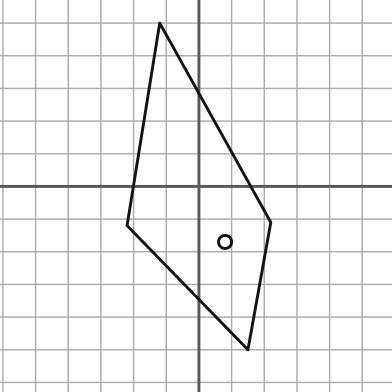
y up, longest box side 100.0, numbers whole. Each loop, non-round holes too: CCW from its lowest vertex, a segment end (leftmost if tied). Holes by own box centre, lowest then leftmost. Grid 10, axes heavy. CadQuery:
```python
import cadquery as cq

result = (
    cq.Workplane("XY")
    .moveTo(15.0, -50.0)
    .lineTo(22.0, -11.0)
    .lineTo(-12.0, 50.0)
    .lineTo(-22.0, -12.0)
    .close()
    .moveTo(8.0, -17.0)
    .circle(2.0)
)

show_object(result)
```